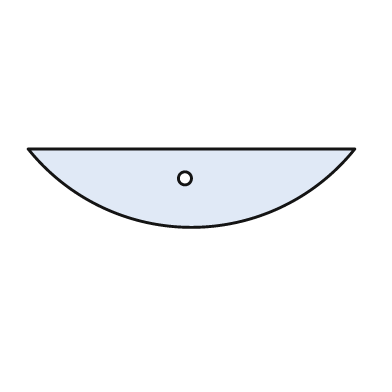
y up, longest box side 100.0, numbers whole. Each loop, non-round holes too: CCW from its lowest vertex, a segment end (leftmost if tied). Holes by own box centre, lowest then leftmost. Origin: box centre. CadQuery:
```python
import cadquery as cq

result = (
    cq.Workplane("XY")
    .moveTo(-50.0, 12.0)
    .threePointArc((0.0, -12.0), (50.0, 12.0))
    .close()
    .moveTo(-2.0, 3.0)
    .circle(2.0)
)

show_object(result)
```